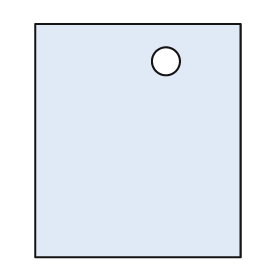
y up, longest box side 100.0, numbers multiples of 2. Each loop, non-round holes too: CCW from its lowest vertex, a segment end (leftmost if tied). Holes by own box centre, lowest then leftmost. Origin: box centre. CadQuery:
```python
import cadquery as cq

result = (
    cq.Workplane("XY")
    .moveTo(-44.0, -50.0)
    .lineTo(44.0, -50.0)
    .lineTo(44.0, 50.0)
    .lineTo(-44.0, 50.0)
    .close()
    .moveTo(12.0, 34.0)
    .circle(6.0)
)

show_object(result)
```